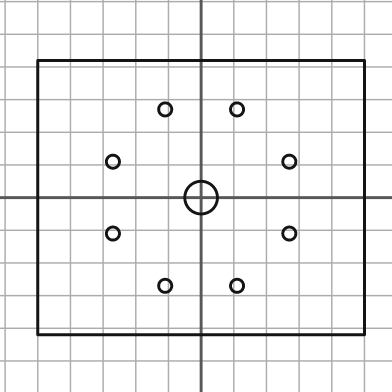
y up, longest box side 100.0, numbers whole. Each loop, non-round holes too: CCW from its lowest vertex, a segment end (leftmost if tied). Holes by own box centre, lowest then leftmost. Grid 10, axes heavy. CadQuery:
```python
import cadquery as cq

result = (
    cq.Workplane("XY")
    .moveTo(-50.0, -42.0)
    .lineTo(50.0, -42.0)
    .lineTo(50.0, 42.0)
    .lineTo(-50.0, 42.0)
    .close()
    .moveTo(-11.0, -27.0)
    .circle(2.0)
    .moveTo(11.0, -27.0)
    .circle(2.0)
    .moveTo(-27.0, -11.0)
    .circle(2.0)
    .moveTo(27.0, -11.0)
    .circle(2.0)
    .moveTo(0.0, 0.0)
    .circle(5.0)
    .moveTo(-27.0, 11.0)
    .circle(2.0)
    .moveTo(27.0, 11.0)
    .circle(2.0)
    .moveTo(-11.0, 27.0)
    .circle(2.0)
    .moveTo(11.0, 27.0)
    .circle(2.0)
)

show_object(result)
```